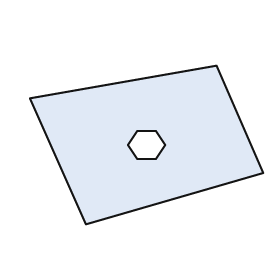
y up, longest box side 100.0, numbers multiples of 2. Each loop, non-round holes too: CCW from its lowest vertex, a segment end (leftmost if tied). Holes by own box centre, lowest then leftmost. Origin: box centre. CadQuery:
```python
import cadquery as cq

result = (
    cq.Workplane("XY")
    .moveTo(-26.0, -34.0)
    .lineTo(50.0, -12.0)
    .lineTo(30.0, 34.0)
    .lineTo(-50.0, 20.0)
    .close()
    .moveTo(-4.0, -6.0)
    .lineTo(4.0, -6.0)
    .lineTo(8.0, 0.0)
    .lineTo(4.0, 6.0)
    .lineTo(-4.0, 6.0)
    .lineTo(-8.0, 0.0)
    .close()
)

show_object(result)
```